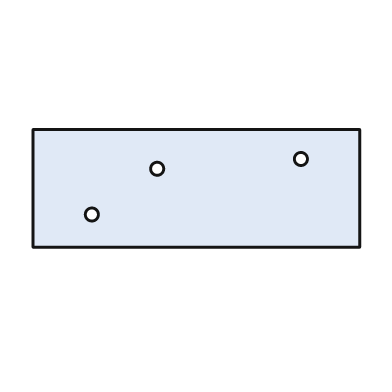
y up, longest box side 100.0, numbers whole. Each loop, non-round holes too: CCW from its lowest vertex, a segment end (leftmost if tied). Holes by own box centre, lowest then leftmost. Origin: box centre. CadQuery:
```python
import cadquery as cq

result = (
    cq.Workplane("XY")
    .moveTo(-50.0, -18.0)
    .lineTo(50.0, -18.0)
    .lineTo(50.0, 18.0)
    .lineTo(-50.0, 18.0)
    .close()
    .moveTo(-32.0, -8.0)
    .circle(2.0)
    .moveTo(-12.0, 6.0)
    .circle(2.0)
    .moveTo(32.0, 9.0)
    .circle(2.0)
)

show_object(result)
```